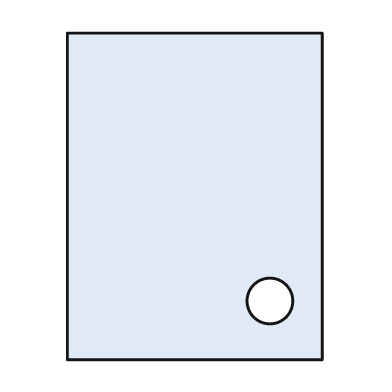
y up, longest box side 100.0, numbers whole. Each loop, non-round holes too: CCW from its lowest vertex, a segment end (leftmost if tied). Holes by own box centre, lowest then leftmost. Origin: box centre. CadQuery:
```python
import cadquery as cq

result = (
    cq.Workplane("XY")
    .moveTo(-39.0, -50.0)
    .lineTo(39.0, -50.0)
    .lineTo(39.0, 50.0)
    .lineTo(-39.0, 50.0)
    .close()
    .moveTo(23.0, -32.0)
    .circle(7.0)
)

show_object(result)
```